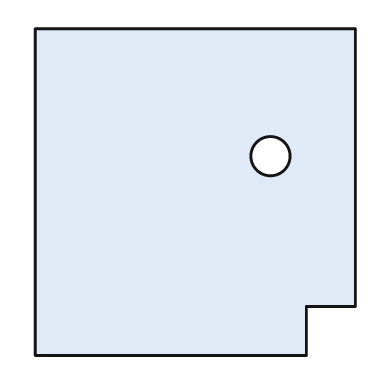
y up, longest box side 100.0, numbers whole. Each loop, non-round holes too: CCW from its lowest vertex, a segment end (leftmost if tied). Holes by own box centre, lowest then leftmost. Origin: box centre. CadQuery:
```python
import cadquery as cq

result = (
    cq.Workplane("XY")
    .moveTo(-49.0, -50.0)
    .lineTo(34.0, -50.0)
    .lineTo(34.0, -35.0)
    .lineTo(49.0, -35.0)
    .lineTo(49.0, 50.0)
    .lineTo(-49.0, 50.0)
    .close()
    .moveTo(23.0, 11.0)
    .circle(6.0)
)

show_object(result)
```